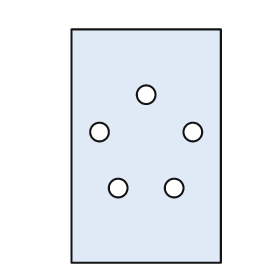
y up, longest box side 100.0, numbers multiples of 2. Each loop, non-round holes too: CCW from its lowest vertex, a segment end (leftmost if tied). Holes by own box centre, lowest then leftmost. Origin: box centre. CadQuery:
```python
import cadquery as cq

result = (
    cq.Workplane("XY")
    .moveTo(-32.0, -50.0)
    .lineTo(32.0, -50.0)
    .lineTo(32.0, 50.0)
    .lineTo(-32.0, 50.0)
    .close()
    .moveTo(-12.0, -18.0)
    .circle(4.0)
    .moveTo(12.0, -18.0)
    .circle(4.0)
    .moveTo(-20.0, 6.0)
    .circle(4.0)
    .moveTo(20.0, 6.0)
    .circle(4.0)
    .moveTo(0.0, 22.0)
    .circle(4.0)
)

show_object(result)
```